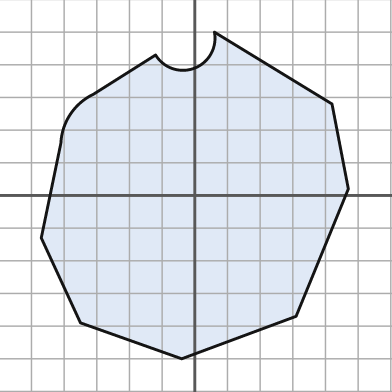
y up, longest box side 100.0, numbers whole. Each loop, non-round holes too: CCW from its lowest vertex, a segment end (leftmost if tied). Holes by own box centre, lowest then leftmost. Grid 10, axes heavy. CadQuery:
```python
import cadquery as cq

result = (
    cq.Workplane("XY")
    .moveTo(-4.0, -50.0)
    .lineTo(31.0, -37.0)
    .lineTo(47.0, 2.0)
    .lineTo(42.0, 28.0)
    .lineTo(6.0, 50.0)
    .threePointArc((0.0, 39.0), (-12.0, 43.0))
    .lineTo(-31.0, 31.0)
    .threePointArc((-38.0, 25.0), (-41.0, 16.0))
    .lineTo(-47.0, -13.0)
    .lineTo(-35.0, -39.0)
    .close()
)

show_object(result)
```